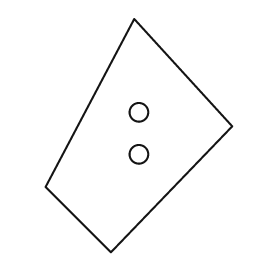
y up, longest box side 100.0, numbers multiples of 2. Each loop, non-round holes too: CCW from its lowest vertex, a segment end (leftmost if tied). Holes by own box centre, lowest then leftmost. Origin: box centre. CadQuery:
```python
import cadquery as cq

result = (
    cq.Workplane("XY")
    .moveTo(-12.0, -50.0)
    .lineTo(40.0, 4.0)
    .lineTo(-2.0, 50.0)
    .lineTo(-40.0, -22.0)
    .close()
    .moveTo(0.0, -8.0)
    .circle(4.0)
    .moveTo(0.0, 10.0)
    .circle(4.0)
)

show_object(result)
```